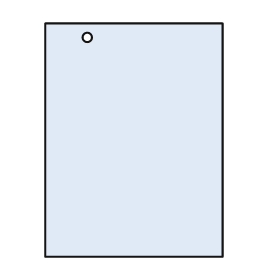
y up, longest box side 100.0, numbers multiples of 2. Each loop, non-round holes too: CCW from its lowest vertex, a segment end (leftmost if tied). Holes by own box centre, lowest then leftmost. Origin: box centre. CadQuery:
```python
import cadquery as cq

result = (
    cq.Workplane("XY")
    .moveTo(-38.0, -50.0)
    .lineTo(38.0, -50.0)
    .lineTo(38.0, 50.0)
    .lineTo(-38.0, 50.0)
    .close()
    .moveTo(-20.0, 44.0)
    .circle(2.0)
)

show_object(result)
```